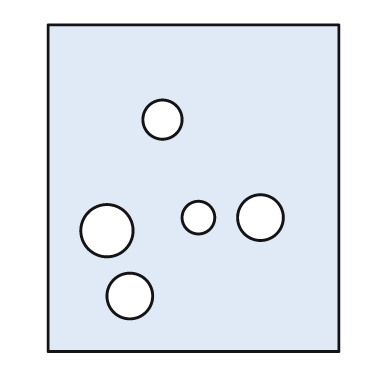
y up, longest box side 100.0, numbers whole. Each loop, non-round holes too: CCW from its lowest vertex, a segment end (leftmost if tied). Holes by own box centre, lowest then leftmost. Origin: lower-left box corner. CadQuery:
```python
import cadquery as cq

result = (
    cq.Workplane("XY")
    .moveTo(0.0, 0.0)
    .lineTo(89.0, 0.0)
    .lineTo(89.0, 100.0)
    .lineTo(0.0, 100.0)
    .close()
    .moveTo(25.0, 17.0)
    .circle(7.0)
    .moveTo(18.0, 37.0)
    .circle(8.0)
    .moveTo(46.0, 41.0)
    .circle(5.0)
    .moveTo(65.0, 41.0)
    .circle(7.0)
    .moveTo(35.0, 71.0)
    .circle(6.0)
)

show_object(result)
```